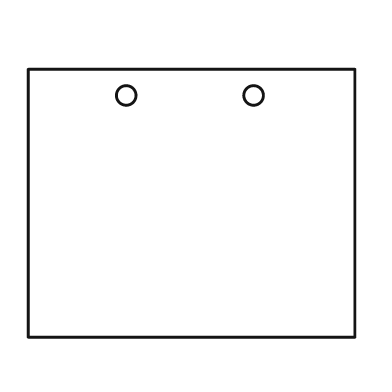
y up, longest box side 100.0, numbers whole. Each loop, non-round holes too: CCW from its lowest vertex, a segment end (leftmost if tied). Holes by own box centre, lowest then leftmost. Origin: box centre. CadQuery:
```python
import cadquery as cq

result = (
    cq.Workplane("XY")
    .moveTo(-50.0, -41.0)
    .lineTo(50.0, -41.0)
    .lineTo(50.0, 41.0)
    .lineTo(-50.0, 41.0)
    .close()
    .moveTo(-20.0, 33.0)
    .circle(3.0)
    .moveTo(19.0, 33.0)
    .circle(3.0)
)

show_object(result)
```